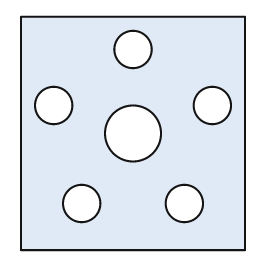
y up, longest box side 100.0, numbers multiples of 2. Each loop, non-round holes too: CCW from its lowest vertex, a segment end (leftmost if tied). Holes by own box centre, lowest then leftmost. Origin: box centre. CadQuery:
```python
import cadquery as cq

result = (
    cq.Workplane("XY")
    .moveTo(-48.0, -50.0)
    .lineTo(48.0, -50.0)
    .lineTo(48.0, 50.0)
    .lineTo(-48.0, 50.0)
    .close()
    .moveTo(-22.0, -30.0)
    .circle(8.0)
    .moveTo(22.0, -30.0)
    .circle(8.0)
    .moveTo(0.0, 0.0)
    .circle(12.0)
    .moveTo(-34.0, 12.0)
    .circle(8.0)
    .moveTo(34.0, 12.0)
    .circle(8.0)
    .moveTo(0.0, 36.0)
    .circle(8.0)
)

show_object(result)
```